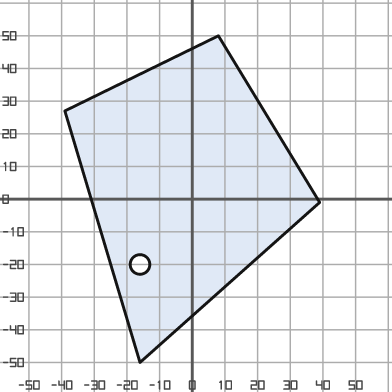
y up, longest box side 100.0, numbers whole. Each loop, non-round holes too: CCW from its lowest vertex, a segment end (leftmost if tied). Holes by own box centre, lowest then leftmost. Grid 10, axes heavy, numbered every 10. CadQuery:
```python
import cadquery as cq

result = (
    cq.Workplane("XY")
    .moveTo(-16.0, -50.0)
    .lineTo(39.0, -1.0)
    .lineTo(8.0, 50.0)
    .lineTo(-39.0, 27.0)
    .close()
    .moveTo(-16.0, -20.0)
    .circle(3.0)
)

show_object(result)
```